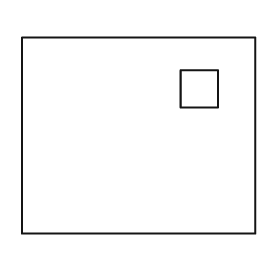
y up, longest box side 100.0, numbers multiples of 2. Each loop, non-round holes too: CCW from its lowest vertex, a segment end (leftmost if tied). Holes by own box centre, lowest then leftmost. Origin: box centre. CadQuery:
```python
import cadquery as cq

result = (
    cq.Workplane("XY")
    .moveTo(-50.0, -42.0)
    .lineTo(50.0, -42.0)
    .lineTo(50.0, 42.0)
    .lineTo(-50.0, 42.0)
    .close()
    .moveTo(18.0, 12.0)
    .lineTo(34.0, 12.0)
    .lineTo(34.0, 28.0)
    .lineTo(18.0, 28.0)
    .close()
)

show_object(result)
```